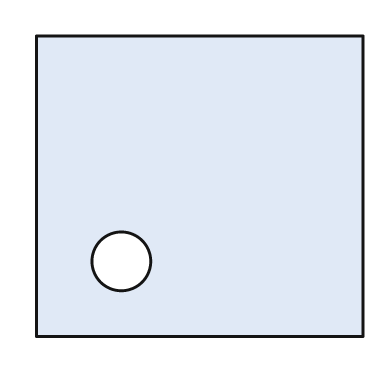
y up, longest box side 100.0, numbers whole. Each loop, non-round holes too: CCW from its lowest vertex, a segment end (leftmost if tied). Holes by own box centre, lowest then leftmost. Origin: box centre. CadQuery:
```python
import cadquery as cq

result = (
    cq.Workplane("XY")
    .moveTo(-50.0, -46.0)
    .lineTo(50.0, -46.0)
    .lineTo(50.0, 46.0)
    .lineTo(-50.0, 46.0)
    .close()
    .moveTo(-24.0, -23.0)
    .circle(9.0)
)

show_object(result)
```